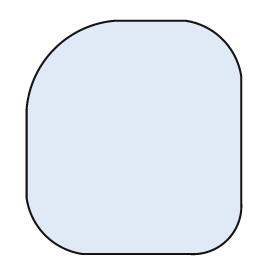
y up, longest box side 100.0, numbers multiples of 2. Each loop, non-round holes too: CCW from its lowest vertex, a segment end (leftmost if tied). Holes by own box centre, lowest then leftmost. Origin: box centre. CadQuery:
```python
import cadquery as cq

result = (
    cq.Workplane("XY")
    .moveTo(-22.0, -50.0)
    .lineTo(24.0, -50.0)
    .threePointArc((40.0, -44.0), (46.0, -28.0))
    .lineTo(46.0, 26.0)
    .threePointArc((38.0, 42.0), (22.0, 50.0))
    .lineTo(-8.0, 50.0)
    .threePointArc((-34.0, 38.0), (-46.0, 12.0))
    .lineTo(-46.0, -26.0)
    .threePointArc((-38.0, -42.0), (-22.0, -50.0))
    .close()
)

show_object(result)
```